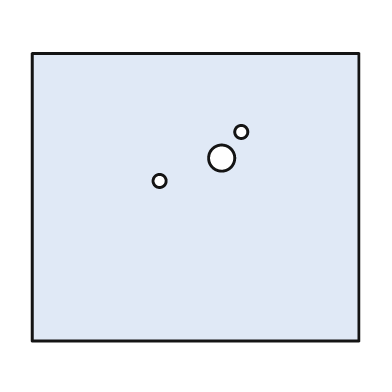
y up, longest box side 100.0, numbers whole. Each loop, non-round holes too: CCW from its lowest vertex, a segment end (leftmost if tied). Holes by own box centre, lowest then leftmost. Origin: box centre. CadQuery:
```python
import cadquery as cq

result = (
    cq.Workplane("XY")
    .moveTo(-50.0, -44.0)
    .lineTo(50.0, -44.0)
    .lineTo(50.0, 44.0)
    .lineTo(-50.0, 44.0)
    .close()
    .moveTo(-11.0, 5.0)
    .circle(2.0)
    .moveTo(8.0, 12.0)
    .circle(4.0)
    .moveTo(14.0, 20.0)
    .circle(2.0)
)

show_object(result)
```